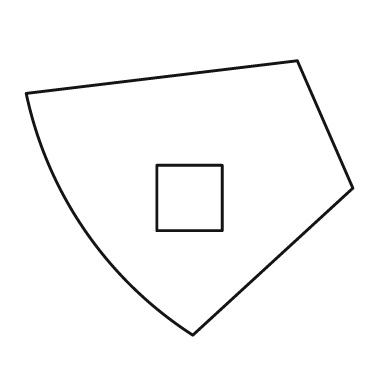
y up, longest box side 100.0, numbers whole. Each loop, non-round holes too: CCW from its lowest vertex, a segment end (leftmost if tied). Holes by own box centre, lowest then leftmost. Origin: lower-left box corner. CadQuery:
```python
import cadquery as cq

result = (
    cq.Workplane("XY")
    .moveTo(51.0, 0.0)
    .lineTo(100.0, 45.0)
    .lineTo(83.0, 84.0)
    .lineTo(0.0, 74.0)
    .threePointArc((18.0, 32.0), (51.0, 0.0))
    .close()
    .moveTo(40.0, 32.0)
    .lineTo(60.0, 32.0)
    .lineTo(60.0, 52.0)
    .lineTo(40.0, 52.0)
    .close()
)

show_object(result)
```